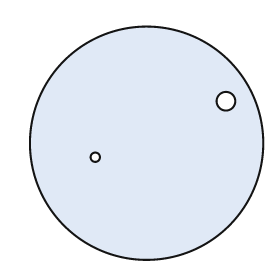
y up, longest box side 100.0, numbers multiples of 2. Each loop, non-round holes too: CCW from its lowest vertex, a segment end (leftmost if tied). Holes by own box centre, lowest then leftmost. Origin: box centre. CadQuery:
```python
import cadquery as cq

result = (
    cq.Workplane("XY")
    .moveTo(0.0, 0.0)
    .circle(50.0)
    .moveTo(-22.0, -6.0)
    .circle(2.0)
    .moveTo(34.0, 18.0)
    .circle(4.0)
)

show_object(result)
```